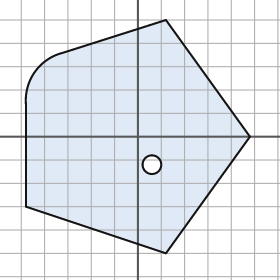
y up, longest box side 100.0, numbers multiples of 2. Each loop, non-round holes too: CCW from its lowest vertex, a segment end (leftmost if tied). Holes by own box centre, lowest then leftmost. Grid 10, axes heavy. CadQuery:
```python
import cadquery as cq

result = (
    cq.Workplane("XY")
    .moveTo(12.0, -50.0)
    .lineTo(48.0, 0.0)
    .lineTo(12.0, 50.0)
    .lineTo(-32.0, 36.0)
    .threePointArc((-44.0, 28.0), (-48.0, 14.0))
    .lineTo(-48.0, -30.0)
    .close()
    .moveTo(6.0, -12.0)
    .circle(4.0)
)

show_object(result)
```